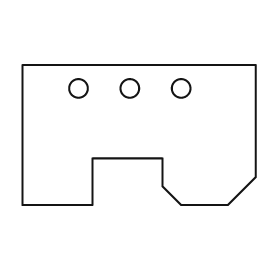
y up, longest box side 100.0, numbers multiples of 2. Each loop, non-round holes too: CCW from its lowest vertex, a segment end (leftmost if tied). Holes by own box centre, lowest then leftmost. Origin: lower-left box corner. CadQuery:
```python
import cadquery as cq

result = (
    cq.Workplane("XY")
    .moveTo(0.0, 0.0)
    .lineTo(30.0, 0.0)
    .lineTo(30.0, 20.0)
    .lineTo(60.0, 20.0)
    .lineTo(60.0, 8.0)
    .lineTo(68.0, 0.0)
    .lineTo(88.0, 0.0)
    .lineTo(100.0, 12.0)
    .lineTo(100.0, 60.0)
    .lineTo(0.0, 60.0)
    .close()
    .moveTo(24.0, 50.0)
    .circle(4.0)
    .moveTo(46.0, 50.0)
    .circle(4.0)
    .moveTo(68.0, 50.0)
    .circle(4.0)
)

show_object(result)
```